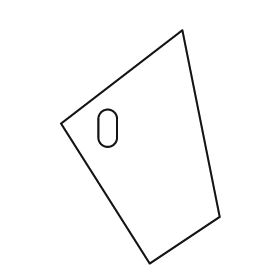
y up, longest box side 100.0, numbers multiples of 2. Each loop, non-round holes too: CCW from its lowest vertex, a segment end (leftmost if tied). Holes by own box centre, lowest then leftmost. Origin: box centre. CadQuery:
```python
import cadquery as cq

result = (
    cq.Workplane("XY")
    .moveTo(4.0, -50.0)
    .lineTo(34.0, -30.0)
    .lineTo(18.0, 50.0)
    .lineTo(-34.0, 10.0)
    .close()
    .moveTo(-18.0, 4.0)
    .threePointArc((-14.0, 0.0), (-10.0, 4.0))
    .lineTo(-10.0, 12.0)
    .threePointArc((-14.0, 16.0), (-18.0, 12.0))
    .close()
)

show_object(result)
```